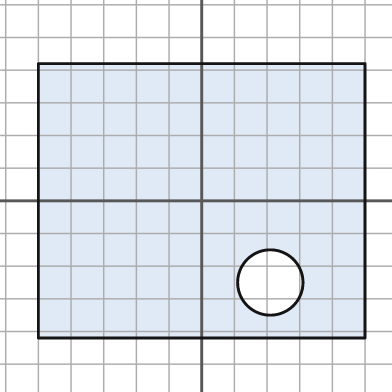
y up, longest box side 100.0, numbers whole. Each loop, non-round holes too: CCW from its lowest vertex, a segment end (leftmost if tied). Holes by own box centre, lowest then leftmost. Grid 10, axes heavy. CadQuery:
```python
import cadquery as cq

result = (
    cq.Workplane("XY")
    .moveTo(-50.0, -42.0)
    .lineTo(50.0, -42.0)
    .lineTo(50.0, 42.0)
    .lineTo(-50.0, 42.0)
    .close()
    .moveTo(21.0, -25.0)
    .circle(10.0)
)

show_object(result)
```